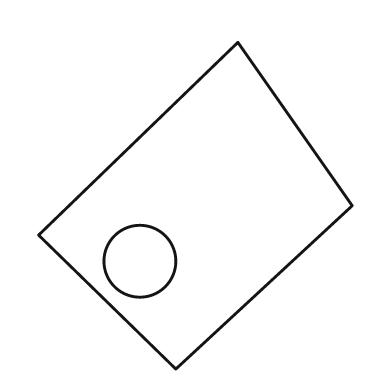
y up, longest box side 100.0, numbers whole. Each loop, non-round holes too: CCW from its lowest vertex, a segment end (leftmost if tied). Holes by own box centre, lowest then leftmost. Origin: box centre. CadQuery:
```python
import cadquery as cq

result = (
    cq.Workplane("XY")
    .moveTo(-6.0, -50.0)
    .lineTo(48.0, 0.0)
    .lineTo(13.0, 50.0)
    .lineTo(-48.0, -9.0)
    .close()
    .moveTo(-17.0, -17.0)
    .circle(11.0)
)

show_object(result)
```